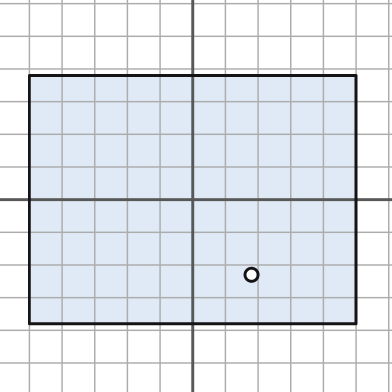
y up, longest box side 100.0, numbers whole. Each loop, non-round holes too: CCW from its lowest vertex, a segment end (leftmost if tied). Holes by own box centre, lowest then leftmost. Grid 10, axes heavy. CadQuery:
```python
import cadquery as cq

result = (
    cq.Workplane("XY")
    .moveTo(-50.0, -38.0)
    .lineTo(50.0, -38.0)
    .lineTo(50.0, 38.0)
    .lineTo(-50.0, 38.0)
    .close()
    .moveTo(18.0, -23.0)
    .circle(2.0)
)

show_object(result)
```